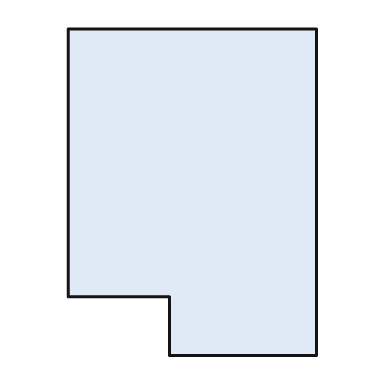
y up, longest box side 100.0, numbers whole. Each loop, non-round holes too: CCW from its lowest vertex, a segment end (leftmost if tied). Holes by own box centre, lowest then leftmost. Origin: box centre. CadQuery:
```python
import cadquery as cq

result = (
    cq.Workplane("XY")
    .moveTo(-7.0, -50.0)
    .lineTo(38.0, -50.0)
    .lineTo(38.0, 50.0)
    .lineTo(-38.0, 50.0)
    .lineTo(-38.0, -32.0)
    .lineTo(-7.0, -32.0)
    .close()
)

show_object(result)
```